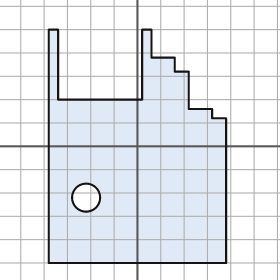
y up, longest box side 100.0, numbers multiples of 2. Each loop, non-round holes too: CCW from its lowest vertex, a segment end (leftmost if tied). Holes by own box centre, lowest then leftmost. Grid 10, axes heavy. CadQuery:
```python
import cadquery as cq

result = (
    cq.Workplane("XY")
    .moveTo(-38.0, -50.0)
    .lineTo(38.0, -50.0)
    .lineTo(38.0, 12.0)
    .lineTo(32.0, 12.0)
    .lineTo(32.0, 16.0)
    .lineTo(22.0, 16.0)
    .lineTo(22.0, 32.0)
    .lineTo(16.0, 32.0)
    .lineTo(16.0, 38.0)
    .lineTo(6.0, 38.0)
    .lineTo(6.0, 50.0)
    .lineTo(2.0, 50.0)
    .lineTo(2.0, 20.0)
    .lineTo(-34.0, 20.0)
    .lineTo(-34.0, 50.0)
    .lineTo(-38.0, 50.0)
    .close()
    .moveTo(-22.0, -22.0)
    .circle(6.0)
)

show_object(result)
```